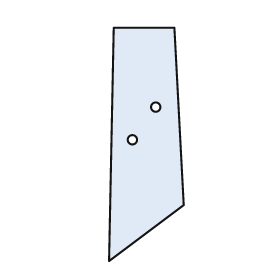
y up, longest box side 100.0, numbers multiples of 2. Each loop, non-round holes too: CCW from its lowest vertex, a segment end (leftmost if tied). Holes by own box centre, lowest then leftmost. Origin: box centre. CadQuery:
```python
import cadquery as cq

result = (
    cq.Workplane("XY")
    .moveTo(-16.0, -50.0)
    .lineTo(16.0, -26.0)
    .lineTo(12.0, 50.0)
    .lineTo(-14.0, 50.0)
    .close()
    .moveTo(-6.0, 2.0)
    .circle(2.0)
    .moveTo(4.0, 16.0)
    .circle(2.0)
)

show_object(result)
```